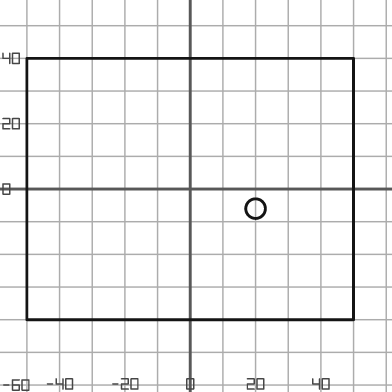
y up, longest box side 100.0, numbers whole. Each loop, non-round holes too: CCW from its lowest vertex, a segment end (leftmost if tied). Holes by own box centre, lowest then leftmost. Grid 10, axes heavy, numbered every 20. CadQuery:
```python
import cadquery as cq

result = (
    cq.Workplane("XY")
    .moveTo(-50.0, -40.0)
    .lineTo(50.0, -40.0)
    .lineTo(50.0, 40.0)
    .lineTo(-50.0, 40.0)
    .close()
    .moveTo(20.0, -6.0)
    .circle(3.0)
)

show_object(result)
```